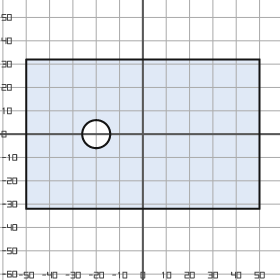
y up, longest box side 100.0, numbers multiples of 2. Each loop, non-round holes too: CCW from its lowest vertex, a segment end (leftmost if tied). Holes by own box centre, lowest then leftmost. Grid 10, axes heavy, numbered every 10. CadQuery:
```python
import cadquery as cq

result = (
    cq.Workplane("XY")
    .moveTo(-50.0, -32.0)
    .lineTo(50.0, -32.0)
    .lineTo(50.0, 32.0)
    .lineTo(-50.0, 32.0)
    .close()
    .moveTo(-20.0, 0.0)
    .circle(6.0)
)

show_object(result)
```